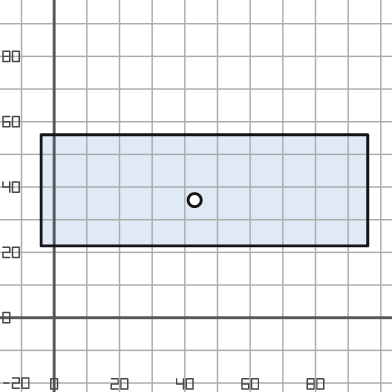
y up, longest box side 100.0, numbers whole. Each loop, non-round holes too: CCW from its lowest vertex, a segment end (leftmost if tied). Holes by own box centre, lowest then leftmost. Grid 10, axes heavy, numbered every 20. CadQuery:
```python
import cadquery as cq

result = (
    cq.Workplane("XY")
    .moveTo(-4.0, 22.0)
    .lineTo(96.0, 22.0)
    .lineTo(96.0, 56.0)
    .lineTo(-4.0, 56.0)
    .close()
    .moveTo(43.0, 36.0)
    .circle(2.0)
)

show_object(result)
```